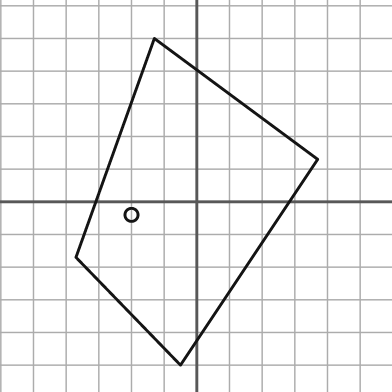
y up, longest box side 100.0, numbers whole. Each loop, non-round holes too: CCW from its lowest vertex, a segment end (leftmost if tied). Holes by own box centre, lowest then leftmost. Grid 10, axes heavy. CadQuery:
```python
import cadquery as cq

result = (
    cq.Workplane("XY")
    .moveTo(-5.0, -50.0)
    .lineTo(37.0, 13.0)
    .lineTo(-13.0, 50.0)
    .lineTo(-37.0, -17.0)
    .close()
    .moveTo(-20.0, -4.0)
    .circle(2.0)
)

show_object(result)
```